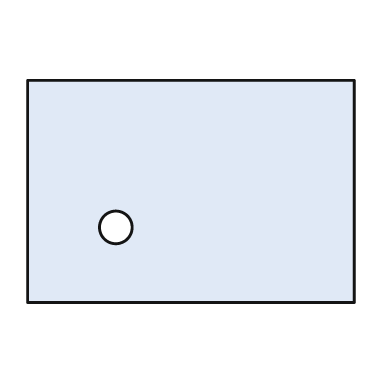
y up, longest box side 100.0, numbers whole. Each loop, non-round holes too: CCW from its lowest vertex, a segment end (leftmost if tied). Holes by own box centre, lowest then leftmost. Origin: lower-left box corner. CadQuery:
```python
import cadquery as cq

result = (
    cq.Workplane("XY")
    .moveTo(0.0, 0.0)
    .lineTo(100.0, 0.0)
    .lineTo(100.0, 68.0)
    .lineTo(0.0, 68.0)
    .close()
    .moveTo(27.0, 23.0)
    .circle(5.0)
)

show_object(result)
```